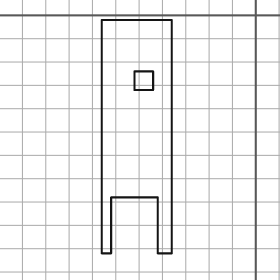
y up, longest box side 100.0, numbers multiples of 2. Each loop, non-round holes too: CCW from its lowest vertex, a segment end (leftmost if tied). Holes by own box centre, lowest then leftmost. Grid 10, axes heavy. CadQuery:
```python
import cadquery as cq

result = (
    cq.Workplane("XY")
    .moveTo(-66.0, -102.0)
    .lineTo(-62.0, -102.0)
    .lineTo(-62.0, -78.0)
    .lineTo(-42.0, -78.0)
    .lineTo(-42.0, -102.0)
    .lineTo(-36.0, -102.0)
    .lineTo(-36.0, -2.0)
    .lineTo(-66.0, -2.0)
    .close()
    .moveTo(-52.0, -32.0)
    .lineTo(-44.0, -32.0)
    .lineTo(-44.0, -24.0)
    .lineTo(-52.0, -24.0)
    .close()
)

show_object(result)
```